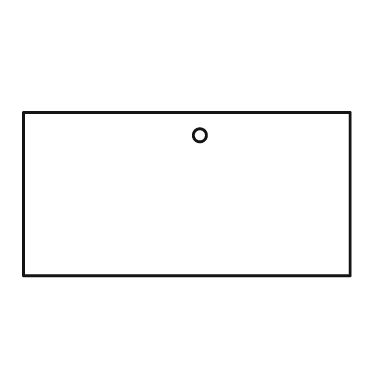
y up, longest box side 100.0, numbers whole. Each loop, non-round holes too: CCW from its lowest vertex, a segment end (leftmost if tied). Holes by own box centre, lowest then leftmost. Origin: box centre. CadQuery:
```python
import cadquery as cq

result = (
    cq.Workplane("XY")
    .moveTo(-50.0, -25.0)
    .lineTo(50.0, -25.0)
    .lineTo(50.0, 25.0)
    .lineTo(-50.0, 25.0)
    .close()
    .moveTo(4.0, 18.0)
    .circle(2.0)
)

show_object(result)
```